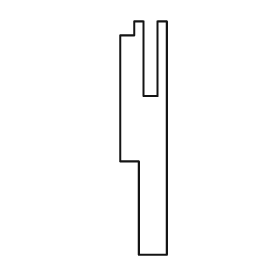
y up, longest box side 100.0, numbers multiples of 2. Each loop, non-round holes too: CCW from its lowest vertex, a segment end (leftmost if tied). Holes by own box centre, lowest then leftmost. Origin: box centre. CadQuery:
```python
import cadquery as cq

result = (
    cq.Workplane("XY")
    .moveTo(-2.0, -50.0)
    .lineTo(10.0, -50.0)
    .lineTo(10.0, 50.0)
    .lineTo(6.0, 50.0)
    .lineTo(6.0, 18.0)
    .lineTo(0.0, 18.0)
    .lineTo(0.0, 50.0)
    .lineTo(-4.0, 50.0)
    .lineTo(-4.0, 44.0)
    .lineTo(-10.0, 44.0)
    .lineTo(-10.0, -10.0)
    .lineTo(-2.0, -10.0)
    .close()
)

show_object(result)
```